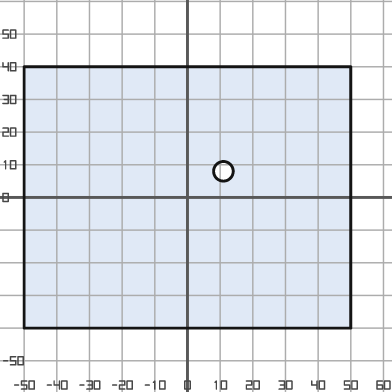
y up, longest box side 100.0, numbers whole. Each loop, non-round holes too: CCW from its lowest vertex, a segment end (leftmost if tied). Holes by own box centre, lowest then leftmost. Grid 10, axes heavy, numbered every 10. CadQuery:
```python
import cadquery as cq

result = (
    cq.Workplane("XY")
    .moveTo(-50.0, -40.0)
    .lineTo(50.0, -40.0)
    .lineTo(50.0, 40.0)
    .lineTo(-50.0, 40.0)
    .close()
    .moveTo(11.0, 8.0)
    .circle(3.0)
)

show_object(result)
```